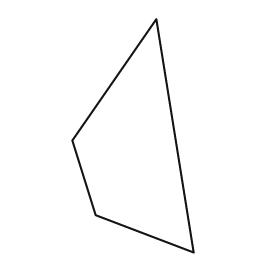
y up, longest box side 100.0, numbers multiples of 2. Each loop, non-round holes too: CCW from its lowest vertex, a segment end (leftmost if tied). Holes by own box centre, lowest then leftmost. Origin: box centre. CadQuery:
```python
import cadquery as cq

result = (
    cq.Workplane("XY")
    .moveTo(26.0, -50.0)
    .lineTo(10.0, 50.0)
    .lineTo(-26.0, -2.0)
    .lineTo(-16.0, -34.0)
    .close()
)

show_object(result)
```